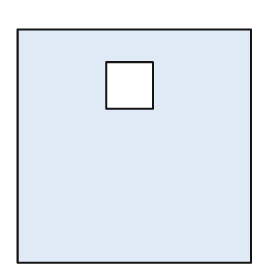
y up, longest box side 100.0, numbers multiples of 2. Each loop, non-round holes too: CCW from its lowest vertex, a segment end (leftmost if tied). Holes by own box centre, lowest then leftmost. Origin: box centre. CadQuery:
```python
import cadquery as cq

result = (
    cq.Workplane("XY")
    .moveTo(-50.0, -50.0)
    .lineTo(50.0, -50.0)
    .lineTo(50.0, 50.0)
    .lineTo(-50.0, 50.0)
    .close()
    .moveTo(-12.0, 16.0)
    .lineTo(8.0, 16.0)
    .lineTo(8.0, 36.0)
    .lineTo(-12.0, 36.0)
    .close()
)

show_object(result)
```